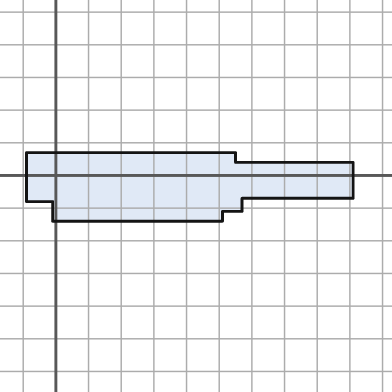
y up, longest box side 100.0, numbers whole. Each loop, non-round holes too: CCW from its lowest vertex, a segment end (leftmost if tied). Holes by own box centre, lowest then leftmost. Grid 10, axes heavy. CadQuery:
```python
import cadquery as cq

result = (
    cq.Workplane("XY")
    .moveTo(-1.0, -14.0)
    .lineTo(51.0, -14.0)
    .lineTo(51.0, -11.0)
    .lineTo(57.0, -11.0)
    .lineTo(57.0, -7.0)
    .lineTo(91.0, -7.0)
    .lineTo(91.0, 4.0)
    .lineTo(55.0, 4.0)
    .lineTo(55.0, 7.0)
    .lineTo(-9.0, 7.0)
    .lineTo(-9.0, -8.0)
    .lineTo(-1.0, -8.0)
    .close()
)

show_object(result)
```